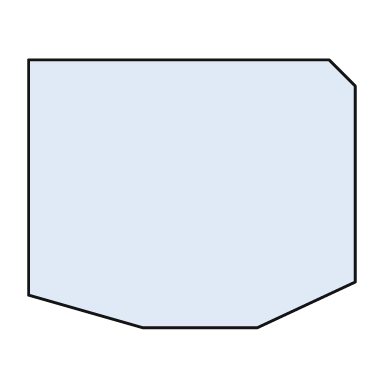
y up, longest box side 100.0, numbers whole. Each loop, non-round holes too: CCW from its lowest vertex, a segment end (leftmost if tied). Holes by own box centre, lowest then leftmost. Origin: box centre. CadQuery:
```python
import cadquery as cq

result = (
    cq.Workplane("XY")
    .moveTo(-15.0, -41.0)
    .lineTo(20.0, -41.0)
    .lineTo(50.0, -27.0)
    .lineTo(50.0, 33.0)
    .lineTo(42.0, 41.0)
    .lineTo(-50.0, 41.0)
    .lineTo(-50.0, -31.0)
    .close()
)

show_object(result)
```